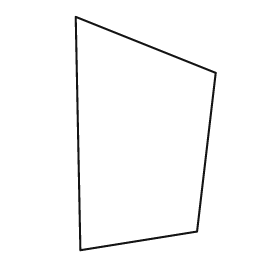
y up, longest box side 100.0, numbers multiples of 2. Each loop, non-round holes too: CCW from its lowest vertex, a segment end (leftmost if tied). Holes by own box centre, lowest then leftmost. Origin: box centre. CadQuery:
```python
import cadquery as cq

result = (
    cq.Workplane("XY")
    .moveTo(-28.0, -50.0)
    .lineTo(22.0, -42.0)
    .lineTo(30.0, 26.0)
    .lineTo(-30.0, 50.0)
    .close()
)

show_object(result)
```